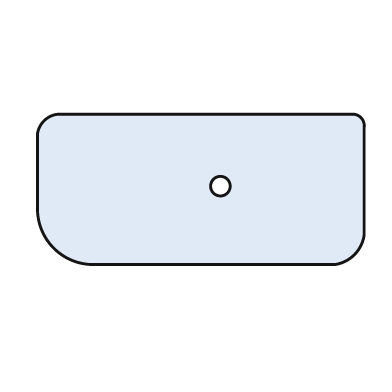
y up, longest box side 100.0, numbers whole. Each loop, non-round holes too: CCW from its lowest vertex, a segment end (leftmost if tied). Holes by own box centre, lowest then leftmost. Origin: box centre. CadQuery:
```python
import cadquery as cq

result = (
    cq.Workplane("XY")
    .moveTo(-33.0, -23.0)
    .lineTo(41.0, -23.0)
    .threePointArc((47.0, -20.0), (50.0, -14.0))
    .lineTo(50.0, 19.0)
    .threePointArc((49.0, 22.0), (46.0, 23.0))
    .lineTo(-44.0, 23.0)
    .threePointArc((-48.0, 21.0), (-50.0, 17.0))
    .lineTo(-50.0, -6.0)
    .threePointArc((-45.0, -18.0), (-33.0, -23.0))
    .close()
    .moveTo(6.0, 1.0)
    .circle(3.0)
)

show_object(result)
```